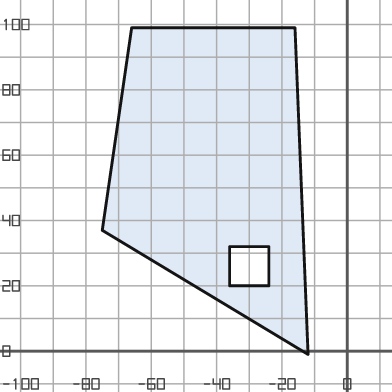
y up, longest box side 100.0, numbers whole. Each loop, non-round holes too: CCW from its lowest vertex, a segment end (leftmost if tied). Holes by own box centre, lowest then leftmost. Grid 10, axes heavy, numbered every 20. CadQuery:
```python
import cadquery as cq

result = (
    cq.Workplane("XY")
    .moveTo(-12.0, -1.0)
    .lineTo(-16.0, 99.0)
    .lineTo(-66.0, 99.0)
    .lineTo(-75.0, 37.0)
    .close()
    .moveTo(-36.0, 20.0)
    .lineTo(-24.0, 20.0)
    .lineTo(-24.0, 32.0)
    .lineTo(-36.0, 32.0)
    .close()
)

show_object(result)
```